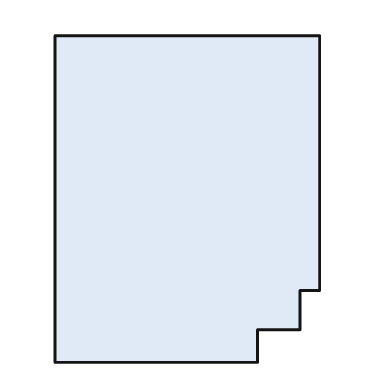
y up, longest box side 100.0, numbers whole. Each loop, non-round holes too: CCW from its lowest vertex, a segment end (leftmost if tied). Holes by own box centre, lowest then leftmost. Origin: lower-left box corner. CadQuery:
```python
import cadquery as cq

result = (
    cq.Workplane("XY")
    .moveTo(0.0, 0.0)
    .lineTo(62.0, 0.0)
    .lineTo(62.0, 10.0)
    .lineTo(75.0, 10.0)
    .lineTo(75.0, 22.0)
    .lineTo(81.0, 22.0)
    .lineTo(81.0, 100.0)
    .lineTo(0.0, 100.0)
    .close()
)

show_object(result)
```